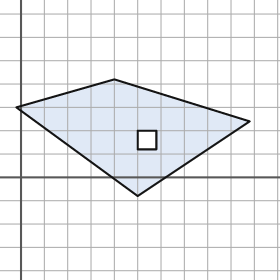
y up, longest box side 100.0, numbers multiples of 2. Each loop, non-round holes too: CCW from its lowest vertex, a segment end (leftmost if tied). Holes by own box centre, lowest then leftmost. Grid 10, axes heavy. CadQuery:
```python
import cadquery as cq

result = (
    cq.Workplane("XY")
    .moveTo(50.0, -8.0)
    .lineTo(98.0, 24.0)
    .lineTo(40.0, 42.0)
    .lineTo(-2.0, 30.0)
    .close()
    .moveTo(50.0, 12.0)
    .lineTo(58.0, 12.0)
    .lineTo(58.0, 20.0)
    .lineTo(50.0, 20.0)
    .close()
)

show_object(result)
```